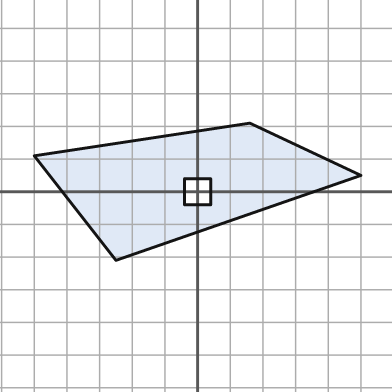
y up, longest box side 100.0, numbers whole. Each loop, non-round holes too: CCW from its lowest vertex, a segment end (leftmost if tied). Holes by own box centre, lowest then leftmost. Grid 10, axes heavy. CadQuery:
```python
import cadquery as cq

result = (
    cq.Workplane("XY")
    .moveTo(-25.0, -21.0)
    .lineTo(50.0, 5.0)
    .lineTo(16.0, 21.0)
    .lineTo(-50.0, 11.0)
    .close()
    .moveTo(-4.0, -4.0)
    .lineTo(4.0, -4.0)
    .lineTo(4.0, 4.0)
    .lineTo(-4.0, 4.0)
    .close()
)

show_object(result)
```